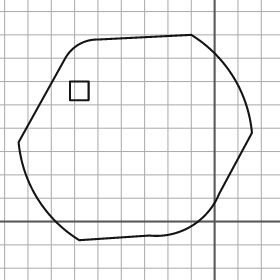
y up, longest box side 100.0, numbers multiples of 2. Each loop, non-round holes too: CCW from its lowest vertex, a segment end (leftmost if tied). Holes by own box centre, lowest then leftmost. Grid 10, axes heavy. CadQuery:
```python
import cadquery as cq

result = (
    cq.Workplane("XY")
    .moveTo(-58.0, -8.0)
    .lineTo(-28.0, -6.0)
    .threePointArc((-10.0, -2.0), (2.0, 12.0))
    .lineTo(16.0, 38.0)
    .threePointArc((8.0, 62.0), (-10.0, 80.0))
    .lineTo(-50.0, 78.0)
    .threePointArc((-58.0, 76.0), (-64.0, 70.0))
    .lineTo(-84.0, 34.0)
    .threePointArc((-76.0, 10.0), (-58.0, -8.0))
    .close()
    .moveTo(-62.0, 52.0)
    .lineTo(-54.0, 52.0)
    .lineTo(-54.0, 60.0)
    .lineTo(-62.0, 60.0)
    .close()
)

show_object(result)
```